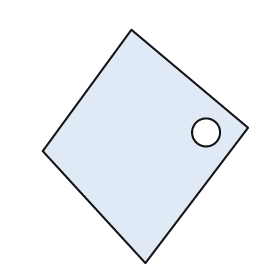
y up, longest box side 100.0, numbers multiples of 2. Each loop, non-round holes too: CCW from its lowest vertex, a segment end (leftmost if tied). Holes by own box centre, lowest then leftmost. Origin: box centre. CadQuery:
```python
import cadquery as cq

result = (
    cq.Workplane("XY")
    .moveTo(0.0, -50.0)
    .lineTo(44.0, 8.0)
    .lineTo(-6.0, 50.0)
    .lineTo(-44.0, -2.0)
    .close()
    .moveTo(26.0, 6.0)
    .circle(6.0)
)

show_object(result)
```